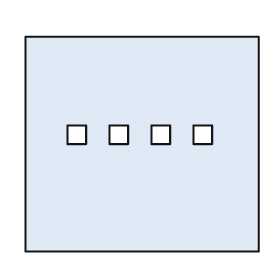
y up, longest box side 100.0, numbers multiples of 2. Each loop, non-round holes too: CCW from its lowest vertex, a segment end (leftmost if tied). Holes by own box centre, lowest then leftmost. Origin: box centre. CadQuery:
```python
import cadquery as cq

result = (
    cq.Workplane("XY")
    .moveTo(-50.0, -46.0)
    .lineTo(50.0, -46.0)
    .lineTo(50.0, 46.0)
    .lineTo(-50.0, 46.0)
    .close()
    .moveTo(-32.0, 0.0)
    .lineTo(-24.0, 0.0)
    .lineTo(-24.0, 8.0)
    .lineTo(-32.0, 8.0)
    .close()
    .moveTo(-14.0, 0.0)
    .lineTo(-6.0, 0.0)
    .lineTo(-6.0, 8.0)
    .lineTo(-14.0, 8.0)
    .close()
    .moveTo(4.0, 0.0)
    .lineTo(12.0, 0.0)
    .lineTo(12.0, 8.0)
    .lineTo(4.0, 8.0)
    .close()
    .moveTo(22.0, 0.0)
    .lineTo(30.0, 0.0)
    .lineTo(30.0, 8.0)
    .lineTo(22.0, 8.0)
    .close()
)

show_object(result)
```